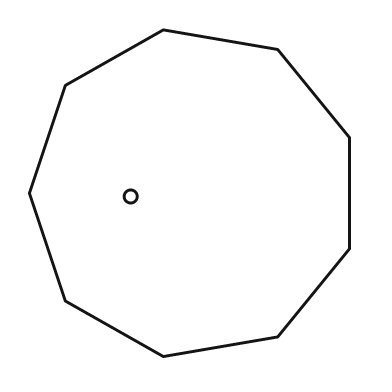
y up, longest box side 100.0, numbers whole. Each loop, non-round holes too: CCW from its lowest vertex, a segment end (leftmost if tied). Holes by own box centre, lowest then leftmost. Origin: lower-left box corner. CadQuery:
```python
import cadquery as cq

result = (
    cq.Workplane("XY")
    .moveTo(41.0, 0.0)
    .lineTo(76.0, 6.0)
    .lineTo(98.0, 33.0)
    .lineTo(98.0, 67.0)
    .lineTo(76.0, 94.0)
    .lineTo(41.0, 100.0)
    .lineTo(11.0, 83.0)
    .lineTo(0.0, 50.0)
    .lineTo(11.0, 17.0)
    .close()
    .moveTo(31.0, 49.0)
    .circle(2.0)
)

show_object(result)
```